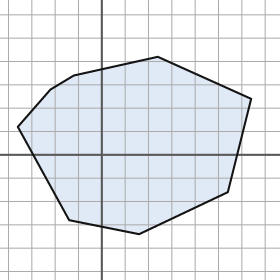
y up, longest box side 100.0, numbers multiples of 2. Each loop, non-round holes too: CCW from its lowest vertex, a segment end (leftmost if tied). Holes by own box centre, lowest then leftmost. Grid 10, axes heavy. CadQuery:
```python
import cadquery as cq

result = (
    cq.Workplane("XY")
    .moveTo(16.0, -34.0)
    .lineTo(54.0, -16.0)
    .lineTo(64.0, 24.0)
    .lineTo(24.0, 42.0)
    .lineTo(-12.0, 34.0)
    .lineTo(-22.0, 28.0)
    .lineTo(-36.0, 12.0)
    .lineTo(-14.0, -28.0)
    .close()
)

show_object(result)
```